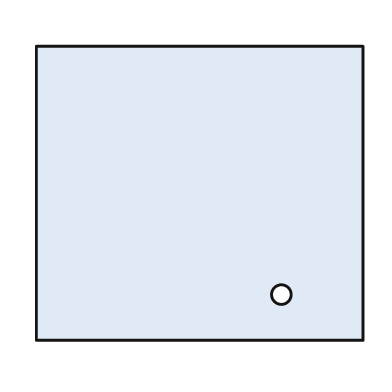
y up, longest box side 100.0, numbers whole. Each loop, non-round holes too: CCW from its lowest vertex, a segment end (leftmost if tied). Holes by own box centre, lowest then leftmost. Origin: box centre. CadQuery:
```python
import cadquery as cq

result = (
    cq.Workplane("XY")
    .moveTo(-50.0, -45.0)
    .lineTo(50.0, -45.0)
    .lineTo(50.0, 45.0)
    .lineTo(-50.0, 45.0)
    .close()
    .moveTo(25.0, -31.0)
    .circle(3.0)
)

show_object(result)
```